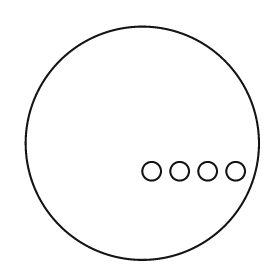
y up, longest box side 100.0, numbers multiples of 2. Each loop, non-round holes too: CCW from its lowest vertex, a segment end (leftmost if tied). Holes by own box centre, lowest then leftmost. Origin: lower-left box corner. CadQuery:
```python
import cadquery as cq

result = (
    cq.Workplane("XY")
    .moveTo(50.0, 50.0)
    .circle(50.0)
    .moveTo(54.0, 38.0)
    .circle(4.0)
    .moveTo(66.0, 38.0)
    .circle(4.0)
    .moveTo(78.0, 38.0)
    .circle(4.0)
    .moveTo(90.0, 38.0)
    .circle(4.0)
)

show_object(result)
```